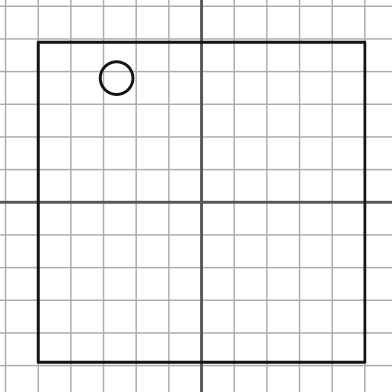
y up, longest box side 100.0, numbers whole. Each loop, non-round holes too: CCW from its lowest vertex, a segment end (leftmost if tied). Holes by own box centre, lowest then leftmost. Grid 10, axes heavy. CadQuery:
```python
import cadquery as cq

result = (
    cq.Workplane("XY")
    .moveTo(-50.0, -49.0)
    .lineTo(50.0, -49.0)
    .lineTo(50.0, 49.0)
    .lineTo(-50.0, 49.0)
    .close()
    .moveTo(-26.0, 38.0)
    .circle(5.0)
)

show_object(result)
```